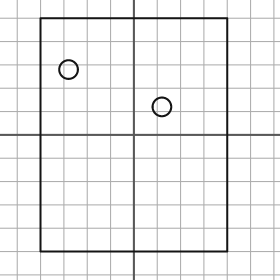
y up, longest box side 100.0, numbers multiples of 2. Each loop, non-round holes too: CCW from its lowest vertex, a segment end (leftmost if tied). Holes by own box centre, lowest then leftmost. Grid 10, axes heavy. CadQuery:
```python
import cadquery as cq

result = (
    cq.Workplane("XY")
    .moveTo(-40.0, -50.0)
    .lineTo(40.0, -50.0)
    .lineTo(40.0, 50.0)
    .lineTo(-40.0, 50.0)
    .close()
    .moveTo(12.0, 12.0)
    .circle(4.0)
    .moveTo(-28.0, 28.0)
    .circle(4.0)
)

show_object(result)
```